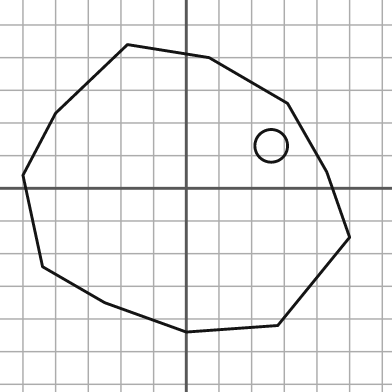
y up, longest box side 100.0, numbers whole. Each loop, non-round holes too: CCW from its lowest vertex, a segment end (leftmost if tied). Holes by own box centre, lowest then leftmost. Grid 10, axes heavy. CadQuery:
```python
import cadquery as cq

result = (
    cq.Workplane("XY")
    .moveTo(0.0, -44.0)
    .lineTo(28.0, -42.0)
    .lineTo(50.0, -15.0)
    .lineTo(43.0, 5.0)
    .lineTo(31.0, 26.0)
    .lineTo(7.0, 40.0)
    .lineTo(-18.0, 44.0)
    .lineTo(-40.0, 23.0)
    .lineTo(-50.0, 4.0)
    .lineTo(-44.0, -24.0)
    .lineTo(-25.0, -35.0)
    .close()
    .moveTo(26.0, 13.0)
    .circle(5.0)
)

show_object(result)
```